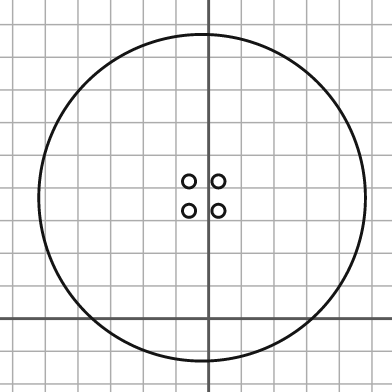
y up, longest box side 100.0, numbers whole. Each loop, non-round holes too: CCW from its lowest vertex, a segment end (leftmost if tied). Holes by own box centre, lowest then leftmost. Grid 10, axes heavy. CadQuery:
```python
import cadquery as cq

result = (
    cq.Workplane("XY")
    .moveTo(-2.0, 37.0)
    .circle(50.0)
    .moveTo(-6.0, 33.0)
    .circle(2.0)
    .moveTo(3.0, 33.0)
    .circle(2.0)
    .moveTo(-6.0, 42.0)
    .circle(2.0)
    .moveTo(3.0, 42.0)
    .circle(2.0)
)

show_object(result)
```